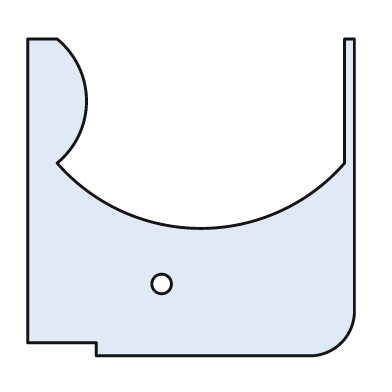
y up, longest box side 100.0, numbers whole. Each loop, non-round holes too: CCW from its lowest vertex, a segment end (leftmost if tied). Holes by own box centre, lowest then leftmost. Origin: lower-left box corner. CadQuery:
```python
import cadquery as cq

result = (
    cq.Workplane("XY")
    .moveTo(21.0, 0.0)
    .lineTo(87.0, 0.0)
    .threePointArc((96.0, 4.0), (100.0, 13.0))
    .lineTo(100.0, 97.0)
    .lineTo(97.0, 97.0)
    .lineTo(97.0, 59.0)
    .threePointArc((53.0, 39.0), (9.0, 59.0))
    .threePointArc((18.0, 78.0), (9.0, 97.0))
    .lineTo(0.0, 97.0)
    .lineTo(0.0, 4.0)
    .lineTo(21.0, 4.0)
    .close()
    .moveTo(41.0, 22.0)
    .circle(3.0)
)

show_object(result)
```